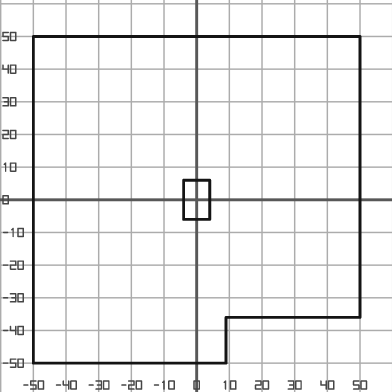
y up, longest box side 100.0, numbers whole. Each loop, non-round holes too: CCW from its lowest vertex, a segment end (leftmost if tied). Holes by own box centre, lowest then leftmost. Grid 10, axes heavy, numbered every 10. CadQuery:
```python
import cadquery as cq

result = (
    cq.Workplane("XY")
    .moveTo(-50.0, -50.0)
    .lineTo(9.0, -50.0)
    .lineTo(9.0, -36.0)
    .lineTo(50.0, -36.0)
    .lineTo(50.0, 50.0)
    .lineTo(-50.0, 50.0)
    .close()
    .moveTo(-4.0, -6.0)
    .lineTo(4.0, -6.0)
    .lineTo(4.0, 6.0)
    .lineTo(-4.0, 6.0)
    .close()
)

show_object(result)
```